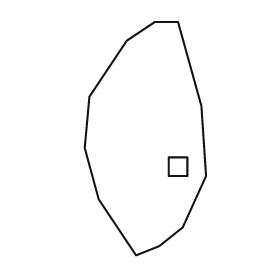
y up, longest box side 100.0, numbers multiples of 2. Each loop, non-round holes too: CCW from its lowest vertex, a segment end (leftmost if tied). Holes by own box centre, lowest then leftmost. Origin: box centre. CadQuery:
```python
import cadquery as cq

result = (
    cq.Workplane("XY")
    .moveTo(-4.0, -50.0)
    .lineTo(6.0, -46.0)
    .lineTo(16.0, -38.0)
    .lineTo(26.0, -16.0)
    .lineTo(24.0, 14.0)
    .lineTo(14.0, 50.0)
    .lineTo(4.0, 50.0)
    .lineTo(-8.0, 42.0)
    .lineTo(-24.0, 18.0)
    .lineTo(-26.0, -4.0)
    .lineTo(-20.0, -26.0)
    .close()
    .moveTo(10.0, -16.0)
    .lineTo(18.0, -16.0)
    .lineTo(18.0, -8.0)
    .lineTo(10.0, -8.0)
    .close()
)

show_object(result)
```